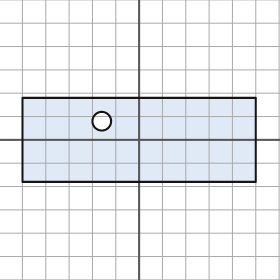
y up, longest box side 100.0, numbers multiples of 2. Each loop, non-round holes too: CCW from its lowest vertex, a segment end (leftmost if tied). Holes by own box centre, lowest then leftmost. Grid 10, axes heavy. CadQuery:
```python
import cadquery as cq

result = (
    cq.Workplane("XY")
    .moveTo(-50.0, -18.0)
    .lineTo(50.0, -18.0)
    .lineTo(50.0, 18.0)
    .lineTo(-50.0, 18.0)
    .close()
    .moveTo(-16.0, 8.0)
    .circle(4.0)
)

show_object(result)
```